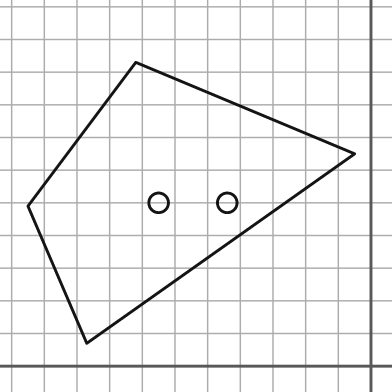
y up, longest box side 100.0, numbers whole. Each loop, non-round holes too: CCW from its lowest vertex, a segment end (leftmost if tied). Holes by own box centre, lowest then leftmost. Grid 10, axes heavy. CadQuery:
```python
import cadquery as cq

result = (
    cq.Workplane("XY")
    .moveTo(-87.0, 7.0)
    .lineTo(-5.0, 65.0)
    .lineTo(-72.0, 93.0)
    .lineTo(-105.0, 49.0)
    .close()
    .moveTo(-65.0, 50.0)
    .circle(3.0)
    .moveTo(-44.0, 50.0)
    .circle(3.0)
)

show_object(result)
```